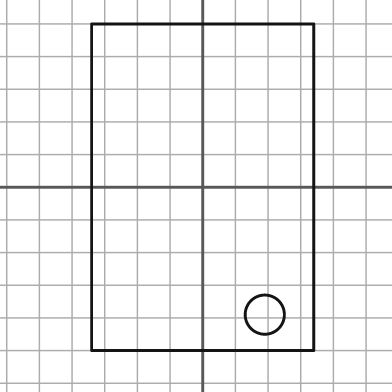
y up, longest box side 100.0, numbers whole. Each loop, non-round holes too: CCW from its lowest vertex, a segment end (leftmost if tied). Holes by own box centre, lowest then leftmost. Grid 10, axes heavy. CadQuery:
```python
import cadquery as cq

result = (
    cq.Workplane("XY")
    .moveTo(-34.0, -50.0)
    .lineTo(34.0, -50.0)
    .lineTo(34.0, 50.0)
    .lineTo(-34.0, 50.0)
    .close()
    .moveTo(19.0, -39.0)
    .circle(6.0)
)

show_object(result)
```